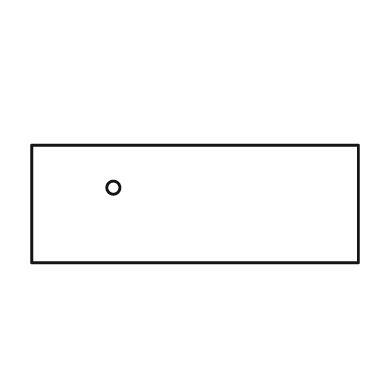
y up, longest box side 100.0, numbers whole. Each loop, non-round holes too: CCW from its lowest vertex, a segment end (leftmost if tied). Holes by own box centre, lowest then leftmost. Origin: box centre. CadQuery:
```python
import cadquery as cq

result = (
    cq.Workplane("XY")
    .moveTo(-50.0, -18.0)
    .lineTo(50.0, -18.0)
    .lineTo(50.0, 18.0)
    .lineTo(-50.0, 18.0)
    .close()
    .moveTo(-25.0, 5.0)
    .circle(2.0)
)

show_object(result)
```